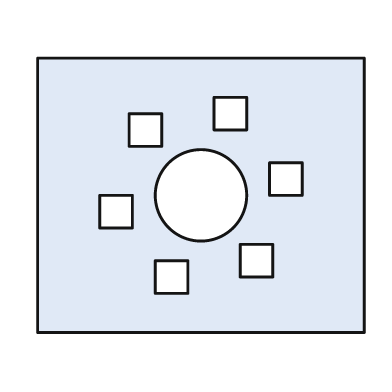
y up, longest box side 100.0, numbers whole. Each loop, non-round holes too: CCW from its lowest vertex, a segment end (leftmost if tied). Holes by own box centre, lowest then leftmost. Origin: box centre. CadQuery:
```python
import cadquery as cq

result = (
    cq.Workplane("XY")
    .moveTo(-50.0, -42.0)
    .lineTo(50.0, -42.0)
    .lineTo(50.0, 42.0)
    .lineTo(-50.0, 42.0)
    .close()
    .moveTo(-14.0, -30.0)
    .lineTo(-4.0, -30.0)
    .lineTo(-4.0, -20.0)
    .lineTo(-14.0, -20.0)
    .close()
    .moveTo(12.0, -25.0)
    .lineTo(22.0, -25.0)
    .lineTo(22.0, -15.0)
    .lineTo(12.0, -15.0)
    .close()
    .moveTo(-31.0, -10.0)
    .lineTo(-21.0, -10.0)
    .lineTo(-21.0, 0.0)
    .lineTo(-31.0, 0.0)
    .close()
    .moveTo(0.0, 0.0)
    .circle(14.0)
    .moveTo(21.0, 0.0)
    .lineTo(31.0, 0.0)
    .lineTo(31.0, 10.0)
    .lineTo(21.0, 10.0)
    .close()
    .moveTo(-22.0, 15.0)
    .lineTo(-12.0, 15.0)
    .lineTo(-12.0, 25.0)
    .lineTo(-22.0, 25.0)
    .close()
    .moveTo(4.0, 20.0)
    .lineTo(14.0, 20.0)
    .lineTo(14.0, 30.0)
    .lineTo(4.0, 30.0)
    .close()
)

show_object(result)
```